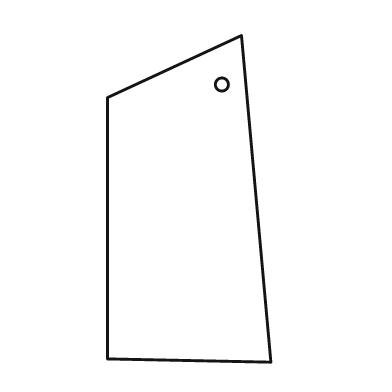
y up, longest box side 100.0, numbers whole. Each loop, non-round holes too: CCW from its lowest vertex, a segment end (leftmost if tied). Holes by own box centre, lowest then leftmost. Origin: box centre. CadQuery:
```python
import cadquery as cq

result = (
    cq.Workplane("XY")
    .moveTo(25.0, -50.0)
    .lineTo(16.0, 50.0)
    .lineTo(-25.0, 31.0)
    .lineTo(-25.0, -49.0)
    .close()
    .moveTo(10.0, 35.0)
    .circle(2.0)
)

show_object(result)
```